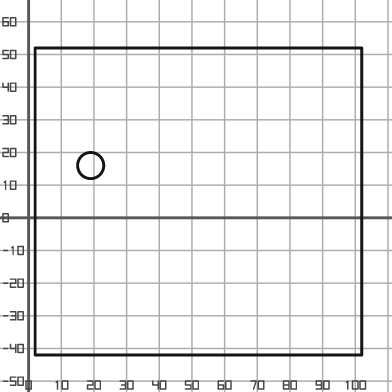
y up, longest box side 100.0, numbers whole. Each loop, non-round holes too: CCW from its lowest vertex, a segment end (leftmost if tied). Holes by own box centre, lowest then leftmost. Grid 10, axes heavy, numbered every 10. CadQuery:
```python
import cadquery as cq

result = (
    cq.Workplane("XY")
    .moveTo(2.0, -42.0)
    .lineTo(102.0, -42.0)
    .lineTo(102.0, 52.0)
    .lineTo(2.0, 52.0)
    .close()
    .moveTo(19.0, 16.0)
    .circle(4.0)
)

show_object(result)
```